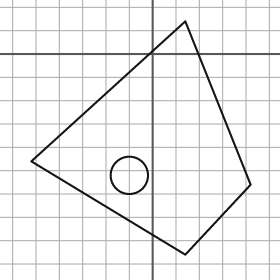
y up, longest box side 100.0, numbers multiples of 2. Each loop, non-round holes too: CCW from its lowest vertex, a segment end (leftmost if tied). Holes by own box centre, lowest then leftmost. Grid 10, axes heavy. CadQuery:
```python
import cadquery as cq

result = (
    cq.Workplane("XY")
    .moveTo(14.0, -86.0)
    .lineTo(42.0, -56.0)
    .lineTo(14.0, 14.0)
    .lineTo(-52.0, -46.0)
    .close()
    .moveTo(-10.0, -52.0)
    .circle(8.0)
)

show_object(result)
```